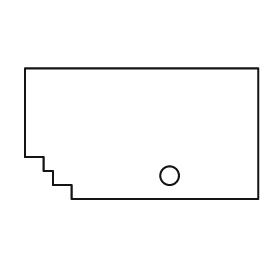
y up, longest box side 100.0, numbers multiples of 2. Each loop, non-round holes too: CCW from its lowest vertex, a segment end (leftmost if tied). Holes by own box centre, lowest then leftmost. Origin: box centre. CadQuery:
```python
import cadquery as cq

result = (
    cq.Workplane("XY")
    .moveTo(-30.0, -28.0)
    .lineTo(50.0, -28.0)
    .lineTo(50.0, 28.0)
    .lineTo(-50.0, 28.0)
    .lineTo(-50.0, -10.0)
    .lineTo(-42.0, -10.0)
    .lineTo(-42.0, -16.0)
    .lineTo(-38.0, -16.0)
    .lineTo(-38.0, -22.0)
    .lineTo(-30.0, -22.0)
    .close()
    .moveTo(12.0, -18.0)
    .circle(4.0)
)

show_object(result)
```